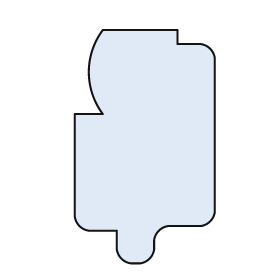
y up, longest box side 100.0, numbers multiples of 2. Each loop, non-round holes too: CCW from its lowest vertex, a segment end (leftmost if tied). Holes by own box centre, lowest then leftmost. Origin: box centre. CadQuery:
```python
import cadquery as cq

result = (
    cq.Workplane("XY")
    .moveTo(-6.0, -50.0)
    .lineTo(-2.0, -50.0)
    .threePointArc((2.0, -48.0), (4.0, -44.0))
    .lineTo(4.0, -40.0)
    .threePointArc((6.0, -36.0), (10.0, -34.0))
    .lineTo(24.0, -34.0)
    .threePointArc((28.0, -32.0), (30.0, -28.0))
    .lineTo(30.0, 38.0)
    .threePointArc((28.0, 42.0), (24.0, 44.0))
    .lineTo(14.0, 44.0)
    .lineTo(14.0, 50.0)
    .lineTo(-18.0, 50.0)
    .threePointArc((-24.0, 32.0), (-18.0, 14.0))
    .lineTo(-30.0, 14.0)
    .lineTo(-30.0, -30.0)
    .threePointArc((-28.0, -34.0), (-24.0, -36.0))
    .lineTo(-12.0, -36.0)
    .lineTo(-12.0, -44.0)
    .threePointArc((-10.0, -48.0), (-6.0, -50.0))
    .close()
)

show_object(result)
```